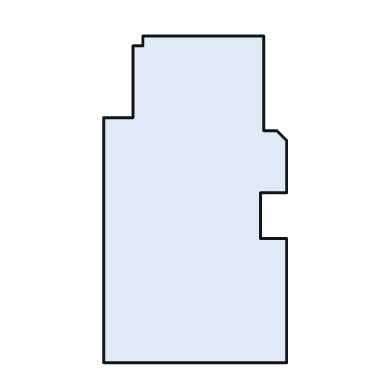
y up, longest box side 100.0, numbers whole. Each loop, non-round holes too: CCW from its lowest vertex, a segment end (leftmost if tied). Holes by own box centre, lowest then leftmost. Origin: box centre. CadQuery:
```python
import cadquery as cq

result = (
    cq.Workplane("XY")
    .moveTo(-28.0, -50.0)
    .lineTo(28.0, -50.0)
    .lineTo(28.0, -12.0)
    .lineTo(20.0, -12.0)
    .lineTo(20.0, 2.0)
    .lineTo(28.0, 2.0)
    .lineTo(28.0, 18.0)
    .lineTo(25.0, 21.0)
    .lineTo(21.0, 21.0)
    .lineTo(21.0, 50.0)
    .lineTo(-16.0, 50.0)
    .lineTo(-16.0, 47.0)
    .lineTo(-19.0, 47.0)
    .lineTo(-19.0, 25.0)
    .lineTo(-28.0, 25.0)
    .close()
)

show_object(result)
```